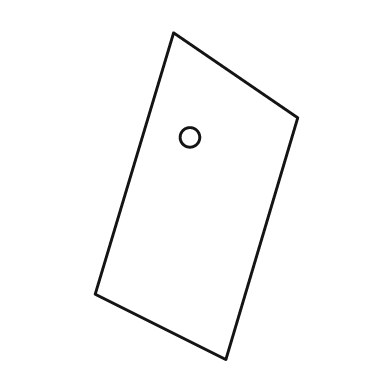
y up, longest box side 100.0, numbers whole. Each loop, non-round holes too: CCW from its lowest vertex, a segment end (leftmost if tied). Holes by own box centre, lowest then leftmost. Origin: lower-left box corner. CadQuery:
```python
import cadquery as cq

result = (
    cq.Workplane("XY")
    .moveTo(40.0, 0.0)
    .lineTo(62.0, 74.0)
    .lineTo(24.0, 100.0)
    .lineTo(0.0, 20.0)
    .close()
    .moveTo(29.0, 68.0)
    .circle(3.0)
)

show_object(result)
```